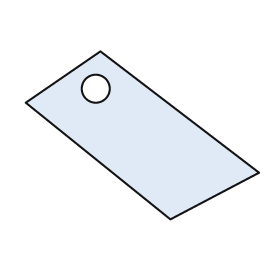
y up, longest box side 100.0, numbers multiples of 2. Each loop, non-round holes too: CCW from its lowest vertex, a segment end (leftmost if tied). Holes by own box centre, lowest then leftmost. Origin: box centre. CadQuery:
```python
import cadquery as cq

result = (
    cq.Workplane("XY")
    .moveTo(12.0, -36.0)
    .lineTo(50.0, -16.0)
    .lineTo(-18.0, 36.0)
    .lineTo(-50.0, 14.0)
    .close()
    .moveTo(-20.0, 20.0)
    .circle(6.0)
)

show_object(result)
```